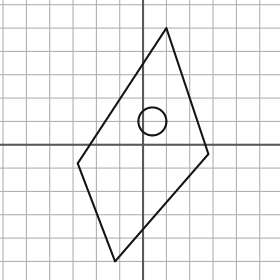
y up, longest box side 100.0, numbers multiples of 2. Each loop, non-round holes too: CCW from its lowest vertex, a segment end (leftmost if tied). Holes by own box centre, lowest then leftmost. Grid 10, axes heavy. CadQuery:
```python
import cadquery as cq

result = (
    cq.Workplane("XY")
    .moveTo(-12.0, -50.0)
    .lineTo(28.0, -4.0)
    .lineTo(10.0, 50.0)
    .lineTo(-28.0, -8.0)
    .close()
    .moveTo(4.0, 10.0)
    .circle(6.0)
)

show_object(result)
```